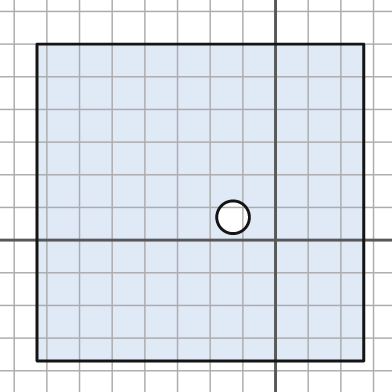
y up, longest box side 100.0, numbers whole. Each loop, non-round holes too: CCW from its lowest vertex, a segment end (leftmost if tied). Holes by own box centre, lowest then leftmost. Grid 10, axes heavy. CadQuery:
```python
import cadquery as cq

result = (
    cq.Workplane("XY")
    .moveTo(-73.0, -37.0)
    .lineTo(27.0, -37.0)
    .lineTo(27.0, 60.0)
    .lineTo(-73.0, 60.0)
    .close()
    .moveTo(-13.0, 7.0)
    .circle(5.0)
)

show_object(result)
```